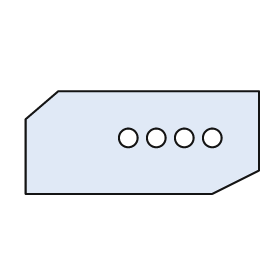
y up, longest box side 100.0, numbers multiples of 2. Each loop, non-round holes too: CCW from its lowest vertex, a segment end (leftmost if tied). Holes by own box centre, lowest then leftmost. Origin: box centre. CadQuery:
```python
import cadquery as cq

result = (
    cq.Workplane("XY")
    .moveTo(-50.0, -22.0)
    .lineTo(30.0, -22.0)
    .lineTo(50.0, -12.0)
    .lineTo(50.0, 22.0)
    .lineTo(-36.0, 22.0)
    .lineTo(-50.0, 10.0)
    .close()
    .moveTo(-6.0, 2.0)
    .circle(4.0)
    .moveTo(6.0, 2.0)
    .circle(4.0)
    .moveTo(18.0, 2.0)
    .circle(4.0)
    .moveTo(30.0, 2.0)
    .circle(4.0)
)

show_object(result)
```